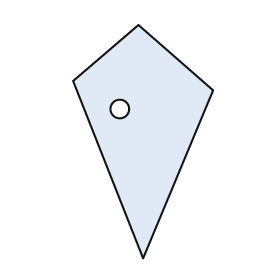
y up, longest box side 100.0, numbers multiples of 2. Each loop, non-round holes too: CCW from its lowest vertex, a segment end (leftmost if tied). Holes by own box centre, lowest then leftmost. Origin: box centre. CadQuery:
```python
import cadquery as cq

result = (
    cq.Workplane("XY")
    .moveTo(0.0, -50.0)
    .lineTo(30.0, 22.0)
    .lineTo(-2.0, 50.0)
    .lineTo(-30.0, 26.0)
    .close()
    .moveTo(-10.0, 14.0)
    .circle(4.0)
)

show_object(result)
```